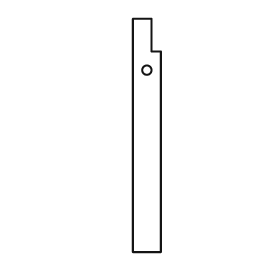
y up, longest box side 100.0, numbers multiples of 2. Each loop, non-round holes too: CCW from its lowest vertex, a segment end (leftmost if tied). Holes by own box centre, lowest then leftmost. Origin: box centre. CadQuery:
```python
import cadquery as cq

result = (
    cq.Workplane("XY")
    .moveTo(-6.0, -50.0)
    .lineTo(6.0, -50.0)
    .lineTo(6.0, 36.0)
    .lineTo(2.0, 36.0)
    .lineTo(2.0, 50.0)
    .lineTo(-6.0, 50.0)
    .close()
    .moveTo(0.0, 28.0)
    .circle(2.0)
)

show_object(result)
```